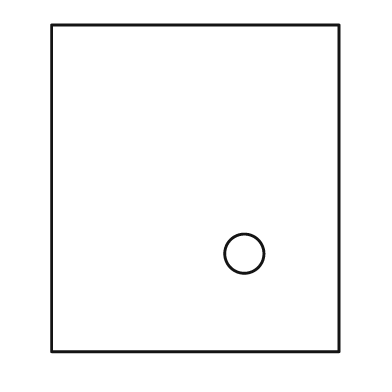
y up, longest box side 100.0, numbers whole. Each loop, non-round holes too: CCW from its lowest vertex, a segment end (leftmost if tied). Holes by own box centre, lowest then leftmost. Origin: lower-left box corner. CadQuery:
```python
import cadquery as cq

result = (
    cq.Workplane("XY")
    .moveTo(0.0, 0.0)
    .lineTo(88.0, 0.0)
    .lineTo(88.0, 100.0)
    .lineTo(0.0, 100.0)
    .close()
    .moveTo(59.0, 30.0)
    .circle(6.0)
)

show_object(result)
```